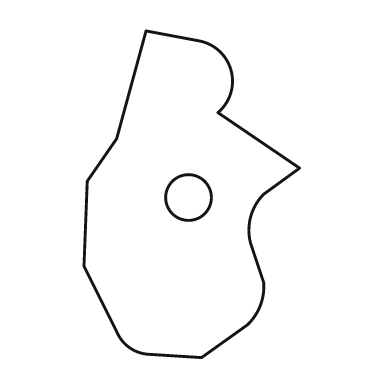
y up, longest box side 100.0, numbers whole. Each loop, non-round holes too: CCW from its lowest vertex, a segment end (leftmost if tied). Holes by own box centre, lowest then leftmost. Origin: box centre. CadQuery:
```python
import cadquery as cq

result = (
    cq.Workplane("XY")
    .moveTo(3.0, -50.0)
    .lineTo(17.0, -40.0)
    .threePointArc((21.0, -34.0), (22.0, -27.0))
    .lineTo(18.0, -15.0)
    .threePointArc((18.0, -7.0), (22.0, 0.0))
    .lineTo(33.0, 8.0)
    .lineTo(8.0, 25.0)
    .threePointArc((12.0, 38.0), (2.0, 47.0))
    .lineTo(-14.0, 50.0)
    .lineTo(-23.0, 17.0)
    .lineTo(-32.0, 4.0)
    .lineTo(-33.0, -22.0)
    .lineTo(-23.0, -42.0)
    .threePointArc((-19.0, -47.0), (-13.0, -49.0))
    .close()
    .moveTo(-1.0, -1.0)
    .circle(7.0)
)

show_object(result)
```